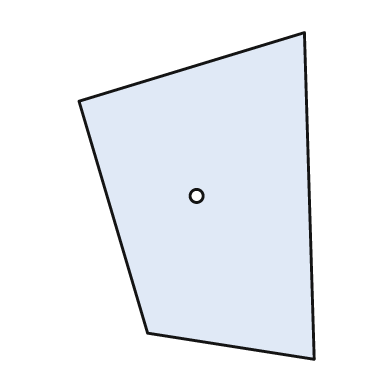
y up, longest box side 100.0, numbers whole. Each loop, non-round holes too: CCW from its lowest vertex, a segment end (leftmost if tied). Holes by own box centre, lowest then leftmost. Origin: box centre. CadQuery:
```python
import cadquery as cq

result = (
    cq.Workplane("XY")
    .moveTo(36.0, -50.0)
    .lineTo(33.0, 50.0)
    .lineTo(-36.0, 29.0)
    .lineTo(-15.0, -42.0)
    .close()
    .moveTo(0.0, 0.0)
    .circle(2.0)
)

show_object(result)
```